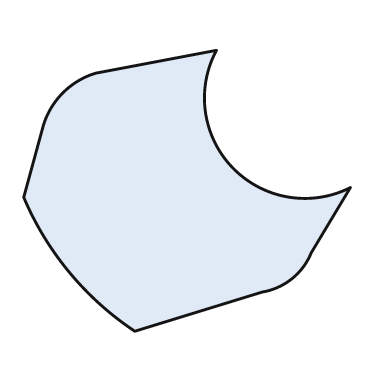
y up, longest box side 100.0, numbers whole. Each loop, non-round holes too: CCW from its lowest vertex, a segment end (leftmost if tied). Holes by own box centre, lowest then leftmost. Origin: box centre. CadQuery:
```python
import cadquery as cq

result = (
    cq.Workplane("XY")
    .moveTo(-16.0, -43.0)
    .lineTo(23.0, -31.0)
    .threePointArc((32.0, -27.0), (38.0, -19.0))
    .lineTo(50.0, 1.0)
    .threePointArc((14.0, 7.0), (9.0, 43.0))
    .lineTo(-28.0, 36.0)
    .threePointArc((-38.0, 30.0), (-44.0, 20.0))
    .lineTo(-50.0, -2.0)
    .threePointArc((-36.0, -25.0), (-16.0, -43.0))
    .close()
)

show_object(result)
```